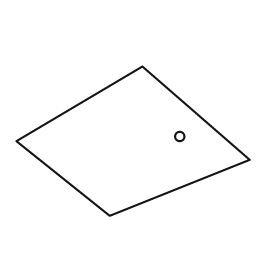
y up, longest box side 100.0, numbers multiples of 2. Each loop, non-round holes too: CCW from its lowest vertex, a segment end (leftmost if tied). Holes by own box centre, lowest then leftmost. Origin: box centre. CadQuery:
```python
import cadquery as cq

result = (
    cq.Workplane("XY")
    .moveTo(-10.0, -32.0)
    .lineTo(50.0, -8.0)
    .lineTo(4.0, 32.0)
    .lineTo(-50.0, 0.0)
    .close()
    .moveTo(20.0, 2.0)
    .circle(2.0)
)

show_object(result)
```